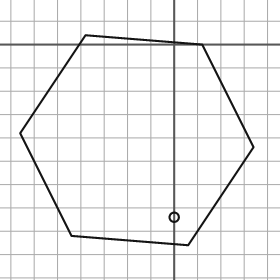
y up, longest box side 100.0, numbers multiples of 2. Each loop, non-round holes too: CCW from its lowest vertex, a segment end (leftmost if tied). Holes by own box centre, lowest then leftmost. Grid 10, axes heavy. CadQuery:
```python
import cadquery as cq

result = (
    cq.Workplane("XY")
    .moveTo(6.0, -86.0)
    .lineTo(34.0, -44.0)
    .lineTo(12.0, 0.0)
    .lineTo(-38.0, 4.0)
    .lineTo(-66.0, -38.0)
    .lineTo(-44.0, -82.0)
    .close()
    .moveTo(0.0, -74.0)
    .circle(2.0)
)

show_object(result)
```